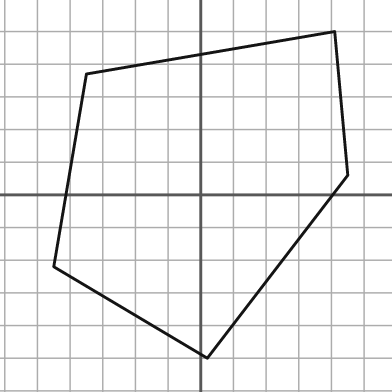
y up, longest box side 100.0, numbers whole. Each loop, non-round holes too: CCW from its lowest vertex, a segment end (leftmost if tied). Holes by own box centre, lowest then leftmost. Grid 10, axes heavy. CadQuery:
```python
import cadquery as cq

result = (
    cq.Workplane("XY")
    .moveTo(2.0, -50.0)
    .lineTo(45.0, 6.0)
    .lineTo(41.0, 50.0)
    .lineTo(-35.0, 37.0)
    .lineTo(-45.0, -22.0)
    .close()
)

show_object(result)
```